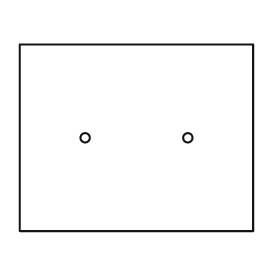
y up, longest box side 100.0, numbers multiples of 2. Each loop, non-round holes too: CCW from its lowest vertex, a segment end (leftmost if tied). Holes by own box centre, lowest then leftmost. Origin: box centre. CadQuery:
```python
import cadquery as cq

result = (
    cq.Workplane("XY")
    .moveTo(-50.0, -40.0)
    .lineTo(50.0, -40.0)
    .lineTo(50.0, 40.0)
    .lineTo(-50.0, 40.0)
    .close()
    .moveTo(-22.0, 0.0)
    .circle(2.0)
    .moveTo(22.0, 0.0)
    .circle(2.0)
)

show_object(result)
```